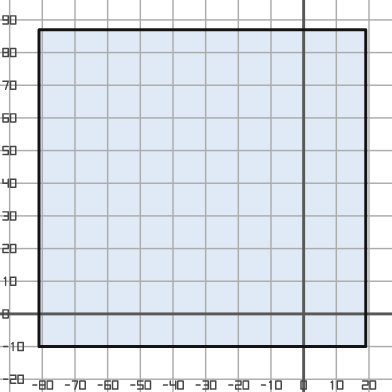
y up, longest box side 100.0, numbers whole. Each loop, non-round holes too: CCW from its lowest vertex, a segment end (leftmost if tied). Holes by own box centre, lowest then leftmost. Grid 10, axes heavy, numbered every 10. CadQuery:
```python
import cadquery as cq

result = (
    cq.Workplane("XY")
    .moveTo(-81.0, -10.0)
    .lineTo(19.0, -10.0)
    .lineTo(19.0, 87.0)
    .lineTo(-81.0, 87.0)
    .close()
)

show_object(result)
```